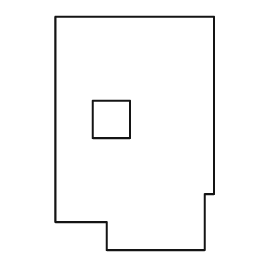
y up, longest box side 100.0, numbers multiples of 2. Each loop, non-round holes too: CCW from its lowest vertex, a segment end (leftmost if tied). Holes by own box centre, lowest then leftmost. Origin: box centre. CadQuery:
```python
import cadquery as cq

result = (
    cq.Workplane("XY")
    .moveTo(-12.0, -50.0)
    .lineTo(30.0, -50.0)
    .lineTo(30.0, -26.0)
    .lineTo(34.0, -26.0)
    .lineTo(34.0, 50.0)
    .lineTo(-34.0, 50.0)
    .lineTo(-34.0, -38.0)
    .lineTo(-12.0, -38.0)
    .close()
    .moveTo(-18.0, -2.0)
    .lineTo(-2.0, -2.0)
    .lineTo(-2.0, 14.0)
    .lineTo(-18.0, 14.0)
    .close()
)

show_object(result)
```